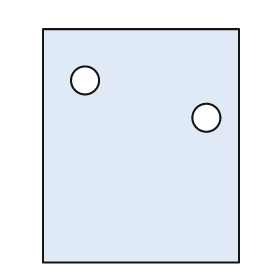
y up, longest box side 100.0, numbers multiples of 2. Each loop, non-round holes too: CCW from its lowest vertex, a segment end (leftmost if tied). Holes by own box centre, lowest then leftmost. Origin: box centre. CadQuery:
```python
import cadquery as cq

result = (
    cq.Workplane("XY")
    .moveTo(-42.0, -50.0)
    .lineTo(42.0, -50.0)
    .lineTo(42.0, 50.0)
    .lineTo(-42.0, 50.0)
    .close()
    .moveTo(28.0, 12.0)
    .circle(6.0)
    .moveTo(-24.0, 28.0)
    .circle(6.0)
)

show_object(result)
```